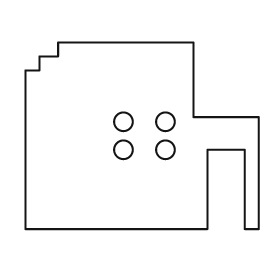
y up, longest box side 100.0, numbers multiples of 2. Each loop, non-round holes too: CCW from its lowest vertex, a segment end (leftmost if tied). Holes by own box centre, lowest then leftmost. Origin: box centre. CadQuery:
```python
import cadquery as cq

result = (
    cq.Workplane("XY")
    .moveTo(-50.0, -40.0)
    .lineTo(28.0, -40.0)
    .lineTo(28.0, -6.0)
    .lineTo(44.0, -6.0)
    .lineTo(44.0, -40.0)
    .lineTo(50.0, -40.0)
    .lineTo(50.0, 8.0)
    .lineTo(22.0, 8.0)
    .lineTo(22.0, 40.0)
    .lineTo(-36.0, 40.0)
    .lineTo(-36.0, 34.0)
    .lineTo(-44.0, 34.0)
    .lineTo(-44.0, 28.0)
    .lineTo(-50.0, 28.0)
    .close()
    .moveTo(-8.0, -6.0)
    .circle(4.0)
    .moveTo(10.0, -6.0)
    .circle(4.0)
    .moveTo(-8.0, 6.0)
    .circle(4.0)
    .moveTo(10.0, 6.0)
    .circle(4.0)
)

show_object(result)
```